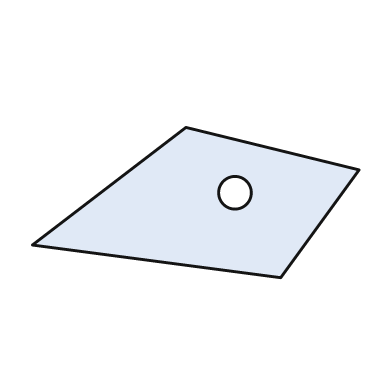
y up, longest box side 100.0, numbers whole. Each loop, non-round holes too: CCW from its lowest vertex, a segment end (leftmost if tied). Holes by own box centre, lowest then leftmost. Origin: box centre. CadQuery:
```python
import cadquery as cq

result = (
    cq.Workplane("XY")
    .moveTo(26.0, -23.0)
    .lineTo(50.0, 10.0)
    .lineTo(-3.0, 23.0)
    .lineTo(-50.0, -13.0)
    .close()
    .moveTo(12.0, 3.0)
    .circle(5.0)
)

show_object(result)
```